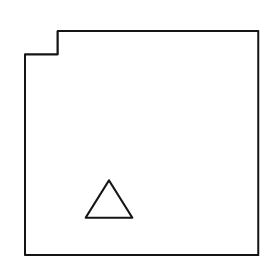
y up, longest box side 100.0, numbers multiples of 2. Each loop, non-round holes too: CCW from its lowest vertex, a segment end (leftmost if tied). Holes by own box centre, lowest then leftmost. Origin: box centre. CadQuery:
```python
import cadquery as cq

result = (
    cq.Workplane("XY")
    .moveTo(-50.0, -48.0)
    .lineTo(50.0, -48.0)
    .lineTo(50.0, 48.0)
    .lineTo(-36.0, 48.0)
    .lineTo(-36.0, 38.0)
    .lineTo(-50.0, 38.0)
    .close()
    .moveTo(-24.0, -32.0)
    .lineTo(-4.0, -32.0)
    .lineTo(-14.0, -16.0)
    .close()
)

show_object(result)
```